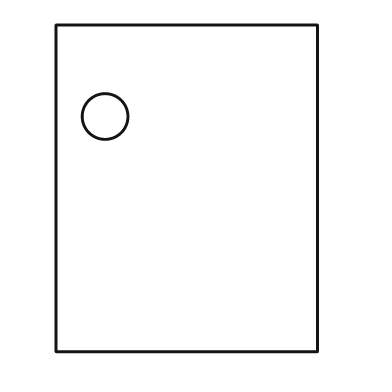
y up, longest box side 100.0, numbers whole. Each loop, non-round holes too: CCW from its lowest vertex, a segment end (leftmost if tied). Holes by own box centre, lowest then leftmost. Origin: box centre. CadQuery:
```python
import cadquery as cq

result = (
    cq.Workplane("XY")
    .moveTo(-40.0, -50.0)
    .lineTo(40.0, -50.0)
    .lineTo(40.0, 50.0)
    .lineTo(-40.0, 50.0)
    .close()
    .moveTo(-25.0, 22.0)
    .circle(7.0)
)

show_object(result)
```